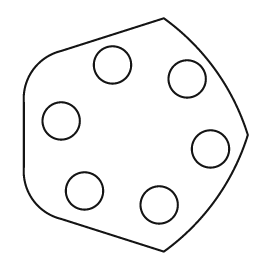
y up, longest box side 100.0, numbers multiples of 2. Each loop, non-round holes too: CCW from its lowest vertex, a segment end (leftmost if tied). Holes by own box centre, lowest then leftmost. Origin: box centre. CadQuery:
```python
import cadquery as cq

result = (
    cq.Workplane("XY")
    .moveTo(12.0, -50.0)
    .threePointArc((34.0, -28.0), (48.0, 0.0))
    .threePointArc((34.0, 28.0), (12.0, 50.0))
    .lineTo(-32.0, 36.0)
    .threePointArc((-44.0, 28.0), (-48.0, 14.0))
    .lineTo(-48.0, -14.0)
    .threePointArc((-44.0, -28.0), (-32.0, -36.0))
    .close()
    .moveTo(10.0, -30.0)
    .circle(8.0)
    .moveTo(-22.0, -24.0)
    .circle(8.0)
    .moveTo(32.0, -6.0)
    .circle(8.0)
    .moveTo(-32.0, 6.0)
    .circle(8.0)
    .moveTo(22.0, 24.0)
    .circle(8.0)
    .moveTo(-10.0, 30.0)
    .circle(8.0)
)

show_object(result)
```